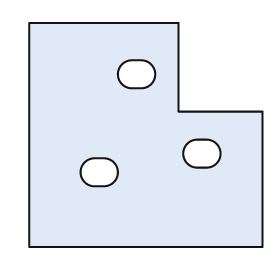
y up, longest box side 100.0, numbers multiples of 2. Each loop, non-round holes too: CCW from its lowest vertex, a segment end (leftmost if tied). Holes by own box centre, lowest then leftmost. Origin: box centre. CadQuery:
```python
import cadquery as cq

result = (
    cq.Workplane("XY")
    .moveTo(-50.0, -48.0)
    .lineTo(50.0, -48.0)
    .lineTo(50.0, 10.0)
    .lineTo(14.0, 10.0)
    .lineTo(14.0, 48.0)
    .lineTo(-50.0, 48.0)
    .close()
    .moveTo(-22.0, -22.0)
    .lineTo(-18.0, -22.0)
    .threePointArc((-12.0, -16.0), (-18.0, -10.0))
    .lineTo(-22.0, -10.0)
    .threePointArc((-28.0, -16.0), (-22.0, -22.0))
    .close()
    .moveTo(22.0, -14.0)
    .lineTo(26.0, -14.0)
    .threePointArc((32.0, -8.0), (26.0, -2.0))
    .lineTo(22.0, -2.0)
    .threePointArc((16.0, -8.0), (22.0, -14.0))
    .close()
    .moveTo(-6.0, 20.0)
    .lineTo(-2.0, 20.0)
    .threePointArc((4.0, 26.0), (-2.0, 32.0))
    .lineTo(-6.0, 32.0)
    .threePointArc((-12.0, 26.0), (-6.0, 20.0))
    .close()
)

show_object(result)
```